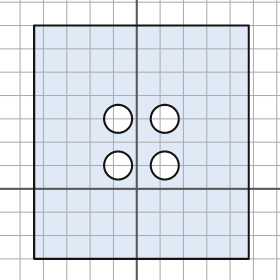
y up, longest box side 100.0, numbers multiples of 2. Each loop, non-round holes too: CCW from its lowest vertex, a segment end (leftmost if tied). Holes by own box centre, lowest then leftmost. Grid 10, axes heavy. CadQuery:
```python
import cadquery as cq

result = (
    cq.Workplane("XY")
    .moveTo(-44.0, -30.0)
    .lineTo(48.0, -30.0)
    .lineTo(48.0, 70.0)
    .lineTo(-44.0, 70.0)
    .close()
    .moveTo(-8.0, 10.0)
    .circle(6.0)
    .moveTo(12.0, 10.0)
    .circle(6.0)
    .moveTo(-8.0, 30.0)
    .circle(6.0)
    .moveTo(12.0, 30.0)
    .circle(6.0)
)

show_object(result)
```